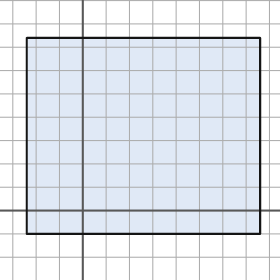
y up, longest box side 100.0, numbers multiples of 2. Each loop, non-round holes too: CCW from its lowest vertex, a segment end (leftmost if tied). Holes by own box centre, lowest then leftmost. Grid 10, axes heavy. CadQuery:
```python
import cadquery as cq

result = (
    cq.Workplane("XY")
    .moveTo(-24.0, -10.0)
    .lineTo(76.0, -10.0)
    .lineTo(76.0, 74.0)
    .lineTo(-24.0, 74.0)
    .close()
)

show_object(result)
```